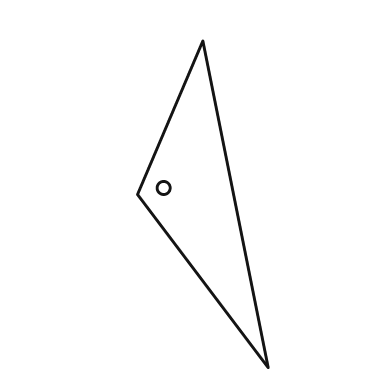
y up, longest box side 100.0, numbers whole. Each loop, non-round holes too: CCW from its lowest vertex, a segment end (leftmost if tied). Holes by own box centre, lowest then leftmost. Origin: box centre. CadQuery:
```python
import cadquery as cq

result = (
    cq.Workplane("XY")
    .moveTo(20.0, -50.0)
    .lineTo(0.0, 50.0)
    .lineTo(-20.0, 3.0)
    .close()
    .moveTo(-12.0, 5.0)
    .circle(2.0)
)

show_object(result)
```